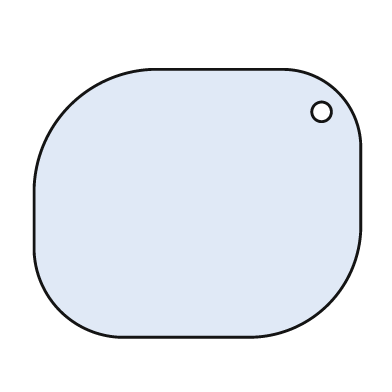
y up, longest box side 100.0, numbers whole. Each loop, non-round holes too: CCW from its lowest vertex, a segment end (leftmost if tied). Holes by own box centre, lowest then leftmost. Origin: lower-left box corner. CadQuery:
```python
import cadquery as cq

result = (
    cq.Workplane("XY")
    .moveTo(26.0, 0.0)
    .lineTo(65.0, 0.0)
    .threePointArc((90.0, 10.0), (100.0, 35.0))
    .lineTo(100.0, 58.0)
    .threePointArc((93.0, 75.0), (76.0, 82.0))
    .lineTo(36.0, 82.0)
    .threePointArc((11.0, 71.0), (0.0, 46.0))
    .lineTo(0.0, 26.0)
    .threePointArc((8.0, 8.0), (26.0, 0.0))
    .close()
    .moveTo(88.0, 69.0)
    .circle(3.0)
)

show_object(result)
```